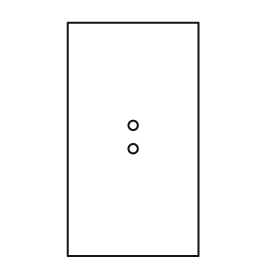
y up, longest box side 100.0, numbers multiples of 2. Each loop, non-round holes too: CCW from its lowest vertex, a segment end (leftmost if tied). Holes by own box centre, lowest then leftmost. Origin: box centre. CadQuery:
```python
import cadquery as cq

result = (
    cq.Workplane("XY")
    .moveTo(-28.0, -50.0)
    .lineTo(28.0, -50.0)
    .lineTo(28.0, 50.0)
    .lineTo(-28.0, 50.0)
    .close()
    .moveTo(0.0, -4.0)
    .circle(2.0)
    .moveTo(0.0, 6.0)
    .circle(2.0)
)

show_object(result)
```